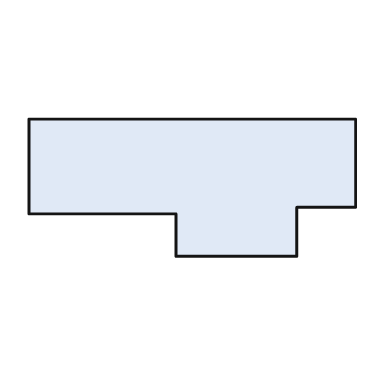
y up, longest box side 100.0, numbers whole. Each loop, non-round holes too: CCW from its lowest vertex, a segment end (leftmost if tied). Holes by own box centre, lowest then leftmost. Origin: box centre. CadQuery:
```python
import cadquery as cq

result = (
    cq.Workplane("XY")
    .moveTo(-5.0, -21.0)
    .lineTo(32.0, -21.0)
    .lineTo(32.0, -6.0)
    .lineTo(50.0, -6.0)
    .lineTo(50.0, 21.0)
    .lineTo(-50.0, 21.0)
    .lineTo(-50.0, -8.0)
    .lineTo(-5.0, -8.0)
    .close()
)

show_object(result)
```